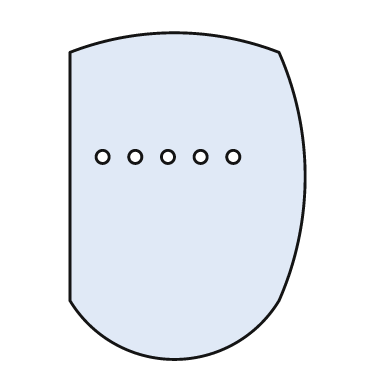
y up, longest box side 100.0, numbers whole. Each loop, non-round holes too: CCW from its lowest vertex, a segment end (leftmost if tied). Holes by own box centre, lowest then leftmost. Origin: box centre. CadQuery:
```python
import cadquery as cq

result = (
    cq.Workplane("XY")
    .moveTo(-36.0, -32.0)
    .threePointArc((-4.0, -50.0), (28.0, -32.0))
    .threePointArc((36.0, 6.0), (28.0, 44.0))
    .threePointArc((-4.0, 50.0), (-36.0, 44.0))
    .close()
    .moveTo(-26.0, 12.0)
    .circle(2.0)
    .moveTo(-16.0, 12.0)
    .circle(2.0)
    .moveTo(-6.0, 12.0)
    .circle(2.0)
    .moveTo(4.0, 12.0)
    .circle(2.0)
    .moveTo(14.0, 12.0)
    .circle(2.0)
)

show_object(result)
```